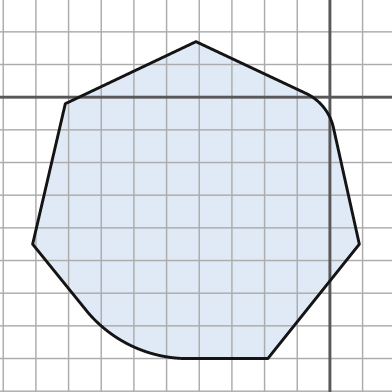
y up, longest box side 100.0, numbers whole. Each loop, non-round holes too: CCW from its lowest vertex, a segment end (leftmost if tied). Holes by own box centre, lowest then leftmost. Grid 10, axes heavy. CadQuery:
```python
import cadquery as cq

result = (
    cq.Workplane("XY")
    .moveTo(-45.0, -80.0)
    .lineTo(-19.0, -80.0)
    .lineTo(9.0, -45.0)
    .lineTo(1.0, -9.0)
    .threePointArc((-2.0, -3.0), (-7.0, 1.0))
    .lineTo(-41.0, 17.0)
    .lineTo(-81.0, -2.0)
    .lineTo(-91.0, -45.0)
    .lineTo(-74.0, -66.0)
    .threePointArc((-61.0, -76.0), (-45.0, -80.0))
    .close()
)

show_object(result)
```